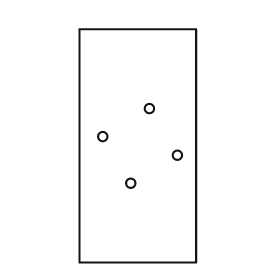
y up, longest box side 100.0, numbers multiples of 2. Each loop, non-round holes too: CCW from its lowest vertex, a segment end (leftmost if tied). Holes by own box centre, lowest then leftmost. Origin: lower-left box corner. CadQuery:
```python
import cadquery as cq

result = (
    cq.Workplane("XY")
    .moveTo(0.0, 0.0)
    .lineTo(50.0, 0.0)
    .lineTo(50.0, 100.0)
    .lineTo(0.0, 100.0)
    .close()
    .moveTo(22.0, 34.0)
    .circle(2.0)
    .moveTo(42.0, 46.0)
    .circle(2.0)
    .moveTo(10.0, 54.0)
    .circle(2.0)
    .moveTo(30.0, 66.0)
    .circle(2.0)
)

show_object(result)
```